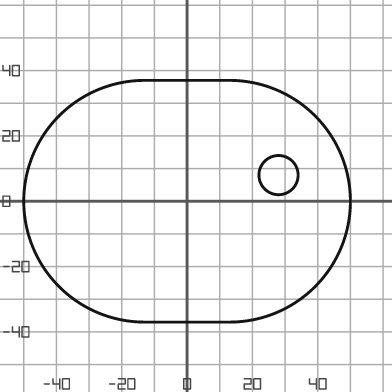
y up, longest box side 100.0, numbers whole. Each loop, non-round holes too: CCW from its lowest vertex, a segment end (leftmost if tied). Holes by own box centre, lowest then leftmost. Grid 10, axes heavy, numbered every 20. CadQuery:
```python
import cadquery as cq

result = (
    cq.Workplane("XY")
    .moveTo(-13.0, -37.0)
    .lineTo(13.0, -37.0)
    .threePointArc((50.0, 0.0), (13.0, 37.0))
    .lineTo(-13.0, 37.0)
    .threePointArc((-50.0, 0.0), (-13.0, -37.0))
    .close()
    .moveTo(28.0, 8.0)
    .circle(6.0)
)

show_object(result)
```